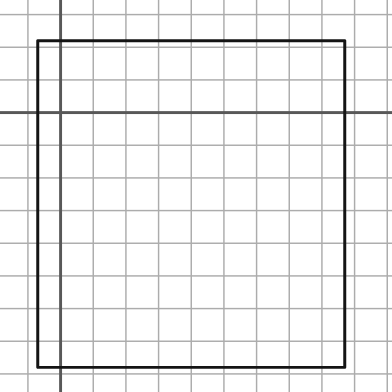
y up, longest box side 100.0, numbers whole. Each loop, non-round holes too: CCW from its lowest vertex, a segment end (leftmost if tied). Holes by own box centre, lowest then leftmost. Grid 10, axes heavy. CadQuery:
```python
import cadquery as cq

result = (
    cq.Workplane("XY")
    .moveTo(-7.0, -78.0)
    .lineTo(87.0, -78.0)
    .lineTo(87.0, 22.0)
    .lineTo(-7.0, 22.0)
    .close()
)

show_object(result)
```